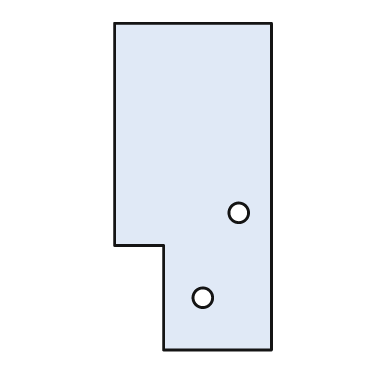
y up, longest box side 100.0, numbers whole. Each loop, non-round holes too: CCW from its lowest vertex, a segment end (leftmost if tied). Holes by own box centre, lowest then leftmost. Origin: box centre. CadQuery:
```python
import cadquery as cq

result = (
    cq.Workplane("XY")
    .moveTo(-9.0, -50.0)
    .lineTo(24.0, -50.0)
    .lineTo(24.0, 50.0)
    .lineTo(-24.0, 50.0)
    .lineTo(-24.0, -18.0)
    .lineTo(-9.0, -18.0)
    .close()
    .moveTo(3.0, -34.0)
    .circle(3.0)
    .moveTo(14.0, -8.0)
    .circle(3.0)
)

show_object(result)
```